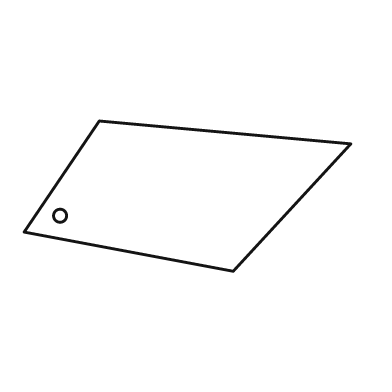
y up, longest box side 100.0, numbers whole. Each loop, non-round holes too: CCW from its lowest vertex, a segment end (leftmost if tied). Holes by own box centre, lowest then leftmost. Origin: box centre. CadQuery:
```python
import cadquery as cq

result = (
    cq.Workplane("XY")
    .moveTo(14.0, -23.0)
    .lineTo(50.0, 16.0)
    .lineTo(-27.0, 23.0)
    .lineTo(-50.0, -11.0)
    .close()
    .moveTo(-39.0, -6.0)
    .circle(2.0)
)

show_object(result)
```